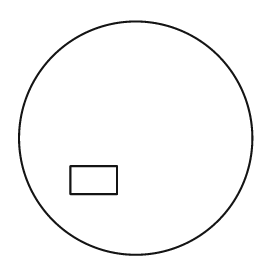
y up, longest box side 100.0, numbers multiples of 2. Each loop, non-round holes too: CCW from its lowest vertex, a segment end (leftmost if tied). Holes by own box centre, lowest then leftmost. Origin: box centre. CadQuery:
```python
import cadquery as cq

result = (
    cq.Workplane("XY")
    .moveTo(0.0, 0.0)
    .circle(50.0)
    .moveTo(-28.0, -24.0)
    .lineTo(-8.0, -24.0)
    .lineTo(-8.0, -12.0)
    .lineTo(-28.0, -12.0)
    .close()
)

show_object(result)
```